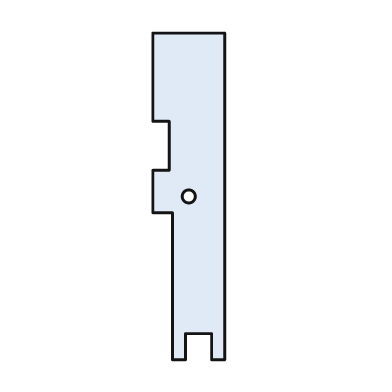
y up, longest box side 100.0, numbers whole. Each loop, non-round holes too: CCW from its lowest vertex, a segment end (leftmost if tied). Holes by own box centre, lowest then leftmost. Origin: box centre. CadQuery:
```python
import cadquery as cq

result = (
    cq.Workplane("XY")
    .moveTo(-5.0, -50.0)
    .lineTo(-1.0, -50.0)
    .lineTo(-1.0, -42.0)
    .lineTo(7.0, -42.0)
    .lineTo(7.0, -50.0)
    .lineTo(11.0, -50.0)
    .lineTo(11.0, 50.0)
    .lineTo(-11.0, 50.0)
    .lineTo(-11.0, 23.0)
    .lineTo(-6.0, 23.0)
    .lineTo(-6.0, 8.0)
    .lineTo(-11.0, 8.0)
    .lineTo(-11.0, -5.0)
    .lineTo(-5.0, -5.0)
    .close()
    .moveTo(0.0, 0.0)
    .circle(2.0)
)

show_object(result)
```